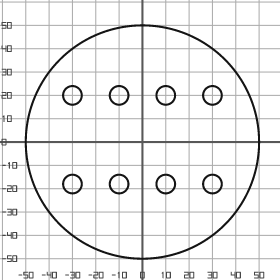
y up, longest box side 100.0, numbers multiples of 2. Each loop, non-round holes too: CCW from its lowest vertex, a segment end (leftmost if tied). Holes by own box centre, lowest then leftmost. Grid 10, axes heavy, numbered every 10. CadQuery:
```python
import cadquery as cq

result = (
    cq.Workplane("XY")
    .moveTo(0.0, 0.0)
    .circle(50.0)
    .moveTo(-30.0, -18.0)
    .circle(4.0)
    .moveTo(-10.0, -18.0)
    .circle(4.0)
    .moveTo(10.0, -18.0)
    .circle(4.0)
    .moveTo(30.0, -18.0)
    .circle(4.0)
    .moveTo(-30.0, 20.0)
    .circle(4.0)
    .moveTo(-10.0, 20.0)
    .circle(4.0)
    .moveTo(10.0, 20.0)
    .circle(4.0)
    .moveTo(30.0, 20.0)
    .circle(4.0)
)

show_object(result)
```